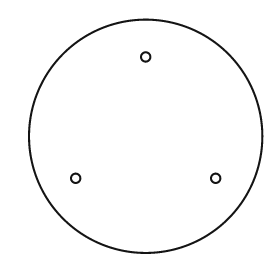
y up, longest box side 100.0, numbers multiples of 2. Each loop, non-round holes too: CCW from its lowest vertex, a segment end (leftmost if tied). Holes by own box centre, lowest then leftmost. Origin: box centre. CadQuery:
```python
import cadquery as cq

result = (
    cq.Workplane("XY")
    .moveTo(0.0, 0.0)
    .circle(50.0)
    .moveTo(-30.0, -18.0)
    .circle(2.0)
    .moveTo(30.0, -18.0)
    .circle(2.0)
    .moveTo(0.0, 34.0)
    .circle(2.0)
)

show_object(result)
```